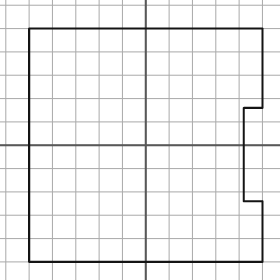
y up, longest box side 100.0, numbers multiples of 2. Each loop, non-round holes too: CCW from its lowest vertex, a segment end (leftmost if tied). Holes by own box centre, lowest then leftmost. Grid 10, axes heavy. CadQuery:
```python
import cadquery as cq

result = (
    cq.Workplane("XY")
    .moveTo(-50.0, -50.0)
    .lineTo(50.0, -50.0)
    .lineTo(50.0, -24.0)
    .lineTo(42.0, -24.0)
    .lineTo(42.0, 16.0)
    .lineTo(50.0, 16.0)
    .lineTo(50.0, 50.0)
    .lineTo(-50.0, 50.0)
    .close()
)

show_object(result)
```